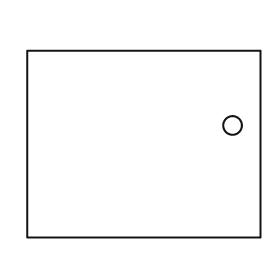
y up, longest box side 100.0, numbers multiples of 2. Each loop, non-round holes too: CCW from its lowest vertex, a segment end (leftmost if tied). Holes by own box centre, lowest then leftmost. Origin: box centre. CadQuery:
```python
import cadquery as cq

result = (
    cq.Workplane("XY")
    .moveTo(-50.0, -40.0)
    .lineTo(50.0, -40.0)
    .lineTo(50.0, 40.0)
    .lineTo(-50.0, 40.0)
    .close()
    .moveTo(38.0, 8.0)
    .circle(4.0)
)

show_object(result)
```